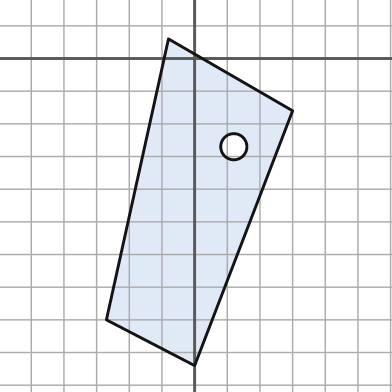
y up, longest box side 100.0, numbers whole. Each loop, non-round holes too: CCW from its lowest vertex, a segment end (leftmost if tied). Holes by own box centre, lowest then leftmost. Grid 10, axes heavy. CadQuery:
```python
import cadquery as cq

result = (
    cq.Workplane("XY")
    .moveTo(0.0, -94.0)
    .lineTo(30.0, -16.0)
    .lineTo(-8.0, 6.0)
    .lineTo(-27.0, -80.0)
    .close()
    .moveTo(12.0, -27.0)
    .circle(4.0)
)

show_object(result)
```